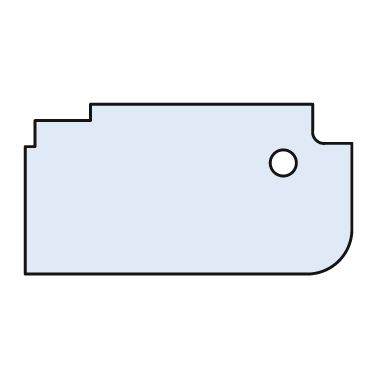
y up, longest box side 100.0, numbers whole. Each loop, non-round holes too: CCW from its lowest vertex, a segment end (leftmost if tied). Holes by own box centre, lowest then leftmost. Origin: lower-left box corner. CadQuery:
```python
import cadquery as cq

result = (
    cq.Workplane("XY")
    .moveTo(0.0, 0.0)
    .lineTo(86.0, 0.0)
    .threePointArc((96.0, 4.0), (100.0, 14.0))
    .lineTo(100.0, 40.0)
    .lineTo(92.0, 40.0)
    .threePointArc((89.0, 41.0), (88.0, 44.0))
    .lineTo(88.0, 52.0)
    .lineTo(20.0, 52.0)
    .lineTo(20.0, 47.0)
    .lineTo(3.0, 47.0)
    .lineTo(3.0, 39.0)
    .lineTo(0.0, 39.0)
    .close()
    .moveTo(79.0, 34.0)
    .circle(4.0)
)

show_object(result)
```